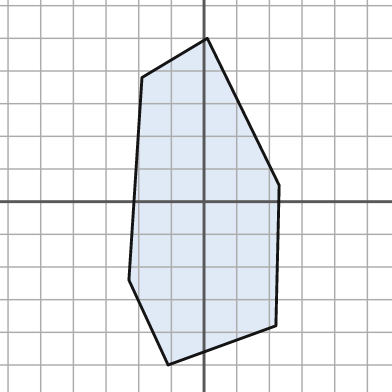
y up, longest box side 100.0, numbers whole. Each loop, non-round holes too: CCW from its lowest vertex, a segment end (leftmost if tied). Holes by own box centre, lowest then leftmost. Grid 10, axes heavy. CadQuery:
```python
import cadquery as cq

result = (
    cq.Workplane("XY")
    .moveTo(-11.0, -50.0)
    .lineTo(22.0, -38.0)
    .lineTo(23.0, 5.0)
    .lineTo(1.0, 50.0)
    .lineTo(-19.0, 38.0)
    .lineTo(-23.0, -24.0)
    .close()
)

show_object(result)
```